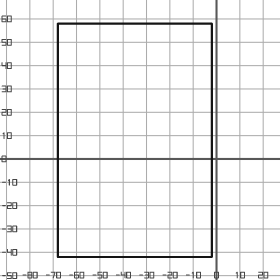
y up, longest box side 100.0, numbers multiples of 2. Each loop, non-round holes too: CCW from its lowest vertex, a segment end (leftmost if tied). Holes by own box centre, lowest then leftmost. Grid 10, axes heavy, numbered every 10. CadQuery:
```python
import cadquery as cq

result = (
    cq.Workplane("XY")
    .moveTo(-68.0, -42.0)
    .lineTo(-2.0, -42.0)
    .lineTo(-2.0, 58.0)
    .lineTo(-68.0, 58.0)
    .close()
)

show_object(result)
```